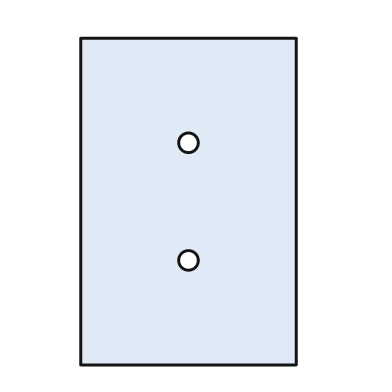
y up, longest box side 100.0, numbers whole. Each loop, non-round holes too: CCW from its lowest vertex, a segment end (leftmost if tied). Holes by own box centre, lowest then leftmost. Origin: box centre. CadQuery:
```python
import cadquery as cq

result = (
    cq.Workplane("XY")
    .moveTo(-33.0, -50.0)
    .lineTo(33.0, -50.0)
    .lineTo(33.0, 50.0)
    .lineTo(-33.0, 50.0)
    .close()
    .moveTo(0.0, -18.0)
    .circle(3.0)
    .moveTo(0.0, 18.0)
    .circle(3.0)
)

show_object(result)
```